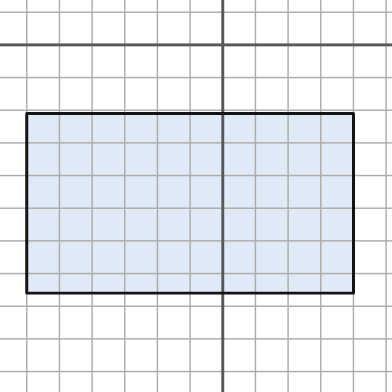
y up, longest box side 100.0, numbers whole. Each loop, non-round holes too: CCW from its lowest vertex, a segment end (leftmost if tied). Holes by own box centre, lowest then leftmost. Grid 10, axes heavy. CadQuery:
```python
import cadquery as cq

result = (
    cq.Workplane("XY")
    .moveTo(-60.0, -76.0)
    .lineTo(40.0, -76.0)
    .lineTo(40.0, -21.0)
    .lineTo(-60.0, -21.0)
    .close()
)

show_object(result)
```